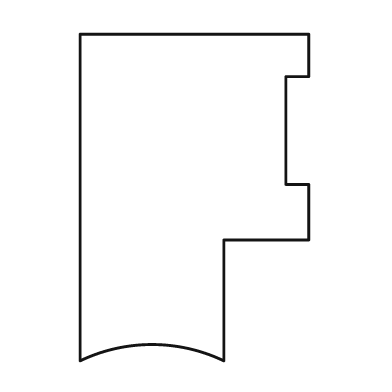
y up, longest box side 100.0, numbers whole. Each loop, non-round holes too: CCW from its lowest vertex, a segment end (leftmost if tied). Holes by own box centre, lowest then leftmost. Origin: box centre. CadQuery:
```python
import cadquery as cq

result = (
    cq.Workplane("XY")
    .moveTo(-35.0, -50.0)
    .threePointArc((-13.0, -45.0), (9.0, -50.0))
    .lineTo(9.0, -13.0)
    .lineTo(35.0, -13.0)
    .lineTo(35.0, 4.0)
    .lineTo(28.0, 4.0)
    .lineTo(28.0, 37.0)
    .lineTo(35.0, 37.0)
    .lineTo(35.0, 50.0)
    .lineTo(-35.0, 50.0)
    .close()
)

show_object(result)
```